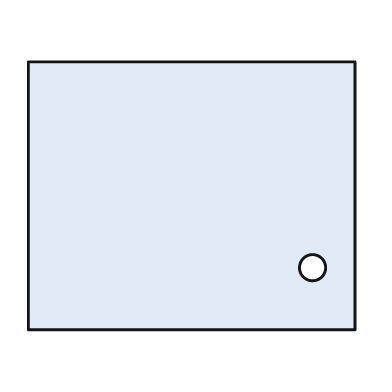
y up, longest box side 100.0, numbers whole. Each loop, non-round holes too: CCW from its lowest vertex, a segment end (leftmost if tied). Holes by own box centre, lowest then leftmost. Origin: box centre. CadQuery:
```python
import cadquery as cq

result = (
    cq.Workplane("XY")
    .moveTo(-50.0, -41.0)
    .lineTo(50.0, -41.0)
    .lineTo(50.0, 41.0)
    .lineTo(-50.0, 41.0)
    .close()
    .moveTo(37.0, -22.0)
    .circle(4.0)
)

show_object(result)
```